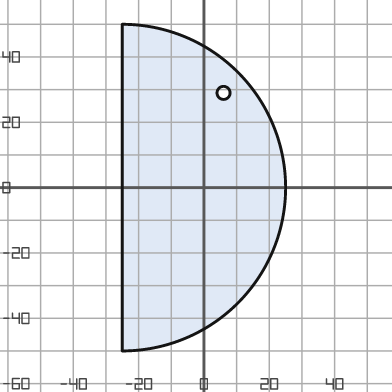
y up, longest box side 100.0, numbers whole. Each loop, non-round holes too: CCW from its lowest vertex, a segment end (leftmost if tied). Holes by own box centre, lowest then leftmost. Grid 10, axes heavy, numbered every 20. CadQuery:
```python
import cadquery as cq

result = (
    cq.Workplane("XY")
    .moveTo(-25.0, -50.0)
    .threePointArc((25.0, 0.0), (-25.0, 50.0))
    .close()
    .moveTo(6.0, 29.0)
    .circle(2.0)
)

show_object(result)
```